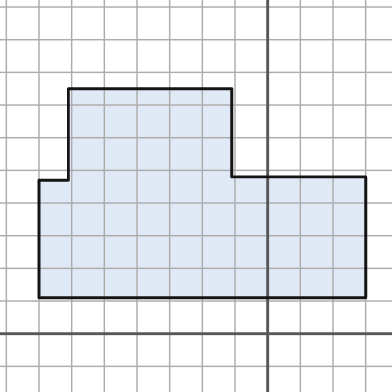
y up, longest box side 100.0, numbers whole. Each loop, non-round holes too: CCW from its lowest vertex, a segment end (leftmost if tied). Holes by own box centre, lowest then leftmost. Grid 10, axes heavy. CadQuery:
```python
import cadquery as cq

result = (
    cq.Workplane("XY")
    .moveTo(-70.0, 11.0)
    .lineTo(30.0, 11.0)
    .lineTo(30.0, 48.0)
    .lineTo(-11.0, 48.0)
    .lineTo(-11.0, 75.0)
    .lineTo(-61.0, 75.0)
    .lineTo(-61.0, 47.0)
    .lineTo(-70.0, 47.0)
    .close()
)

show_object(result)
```